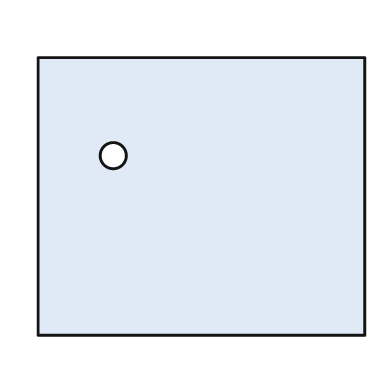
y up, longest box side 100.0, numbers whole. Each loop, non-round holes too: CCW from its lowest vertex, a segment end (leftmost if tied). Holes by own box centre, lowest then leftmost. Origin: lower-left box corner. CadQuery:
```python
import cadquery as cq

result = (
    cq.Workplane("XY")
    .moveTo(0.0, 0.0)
    .lineTo(100.0, 0.0)
    .lineTo(100.0, 85.0)
    .lineTo(0.0, 85.0)
    .close()
    .moveTo(23.0, 55.0)
    .circle(4.0)
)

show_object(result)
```